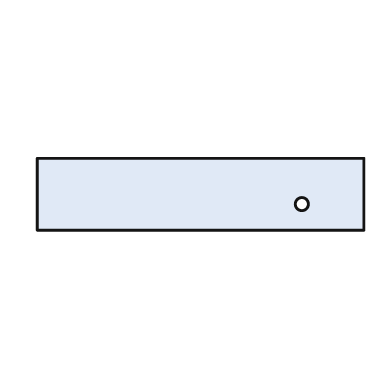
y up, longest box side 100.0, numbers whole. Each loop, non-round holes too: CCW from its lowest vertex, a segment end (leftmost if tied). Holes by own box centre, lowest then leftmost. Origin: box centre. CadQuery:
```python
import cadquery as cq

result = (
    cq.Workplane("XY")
    .moveTo(-50.0, -11.0)
    .lineTo(50.0, -11.0)
    .lineTo(50.0, 11.0)
    .lineTo(-50.0, 11.0)
    .close()
    .moveTo(31.0, -3.0)
    .circle(2.0)
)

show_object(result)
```